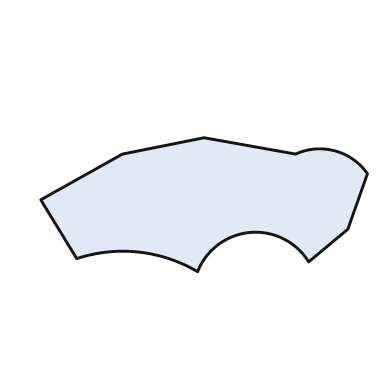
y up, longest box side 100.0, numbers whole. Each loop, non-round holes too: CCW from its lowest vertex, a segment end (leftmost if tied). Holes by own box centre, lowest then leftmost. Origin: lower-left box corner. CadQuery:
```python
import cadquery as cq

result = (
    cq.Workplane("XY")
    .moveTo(48.0, 0.0)
    .threePointArc((64.0, 12.0), (82.0, 3.0))
    .lineTo(94.0, 13.0)
    .lineTo(100.0, 30.0)
    .threePointArc((90.0, 37.0), (78.0, 36.0))
    .lineTo(50.0, 41.0)
    .lineTo(25.0, 36.0)
    .lineTo(0.0, 22.0)
    .lineTo(11.0, 4.0)
    .threePointArc((30.0, 6.0), (48.0, 0.0))
    .close()
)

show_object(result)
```